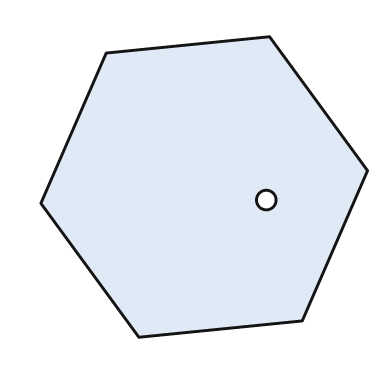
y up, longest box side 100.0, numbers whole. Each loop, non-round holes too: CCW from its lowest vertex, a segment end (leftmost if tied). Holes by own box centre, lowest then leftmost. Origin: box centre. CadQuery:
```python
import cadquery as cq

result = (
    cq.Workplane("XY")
    .moveTo(-20.0, -46.0)
    .lineTo(30.0, -41.0)
    .lineTo(50.0, 5.0)
    .lineTo(20.0, 46.0)
    .lineTo(-30.0, 41.0)
    .lineTo(-50.0, -5.0)
    .close()
    .moveTo(19.0, -4.0)
    .circle(3.0)
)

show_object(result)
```